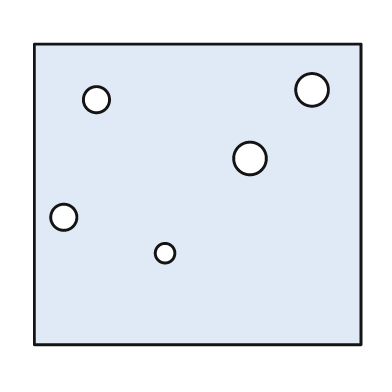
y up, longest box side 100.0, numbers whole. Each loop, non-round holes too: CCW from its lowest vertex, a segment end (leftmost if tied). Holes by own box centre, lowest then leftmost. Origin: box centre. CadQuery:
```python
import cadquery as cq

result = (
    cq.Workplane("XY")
    .moveTo(-50.0, -46.0)
    .lineTo(50.0, -46.0)
    .lineTo(50.0, 46.0)
    .lineTo(-50.0, 46.0)
    .close()
    .moveTo(-10.0, -18.0)
    .circle(3.0)
    .moveTo(-41.0, -7.0)
    .circle(4.0)
    .moveTo(16.0, 11.0)
    .circle(5.0)
    .moveTo(-31.0, 29.0)
    .circle(4.0)
    .moveTo(35.0, 32.0)
    .circle(5.0)
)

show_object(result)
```